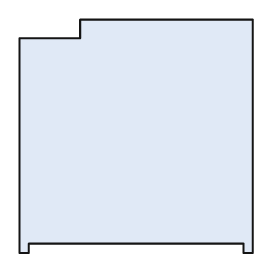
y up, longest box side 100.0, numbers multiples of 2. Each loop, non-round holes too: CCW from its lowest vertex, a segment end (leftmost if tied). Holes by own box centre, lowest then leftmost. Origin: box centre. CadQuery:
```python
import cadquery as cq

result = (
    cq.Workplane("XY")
    .moveTo(-50.0, -50.0)
    .lineTo(-46.0, -50.0)
    .lineTo(-46.0, -46.0)
    .lineTo(46.0, -46.0)
    .lineTo(46.0, -50.0)
    .lineTo(50.0, -50.0)
    .lineTo(50.0, 50.0)
    .lineTo(-24.0, 50.0)
    .lineTo(-24.0, 42.0)
    .lineTo(-50.0, 42.0)
    .close()
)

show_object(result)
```